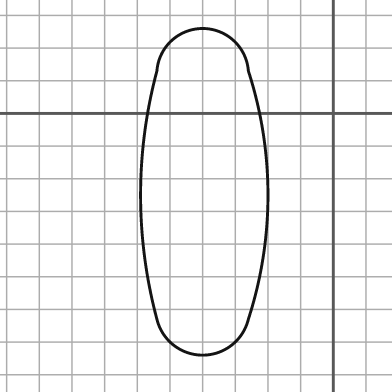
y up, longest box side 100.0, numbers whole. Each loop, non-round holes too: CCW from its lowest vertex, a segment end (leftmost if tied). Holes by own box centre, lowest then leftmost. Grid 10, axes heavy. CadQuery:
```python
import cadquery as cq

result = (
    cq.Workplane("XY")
    .moveTo(-54.0, -63.0)
    .threePointArc((-40.0, -74.0), (-26.0, -63.0))
    .threePointArc((-20.0, -25.0), (-26.0, 13.0))
    .threePointArc((-40.0, 26.0), (-54.0, 13.0))
    .threePointArc((-59.0, -25.0), (-54.0, -63.0))
    .close()
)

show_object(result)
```